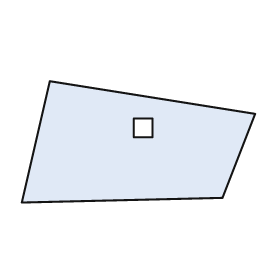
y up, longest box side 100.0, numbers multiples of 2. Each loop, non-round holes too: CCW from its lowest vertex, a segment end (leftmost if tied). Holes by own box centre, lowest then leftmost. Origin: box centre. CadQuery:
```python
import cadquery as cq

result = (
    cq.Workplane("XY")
    .moveTo(-50.0, -26.0)
    .lineTo(36.0, -24.0)
    .lineTo(50.0, 12.0)
    .lineTo(-38.0, 26.0)
    .close()
    .moveTo(-2.0, 2.0)
    .lineTo(6.0, 2.0)
    .lineTo(6.0, 10.0)
    .lineTo(-2.0, 10.0)
    .close()
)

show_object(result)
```